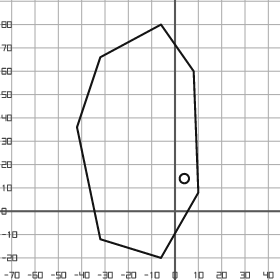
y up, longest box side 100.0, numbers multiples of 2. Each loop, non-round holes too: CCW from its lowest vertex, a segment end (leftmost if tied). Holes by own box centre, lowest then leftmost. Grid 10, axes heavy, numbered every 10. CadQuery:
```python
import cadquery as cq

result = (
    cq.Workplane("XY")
    .moveTo(-6.0, -20.0)
    .lineTo(10.0, 8.0)
    .lineTo(8.0, 60.0)
    .lineTo(-6.0, 80.0)
    .lineTo(-32.0, 66.0)
    .lineTo(-42.0, 36.0)
    .lineTo(-32.0, -12.0)
    .close()
    .moveTo(4.0, 14.0)
    .circle(2.0)
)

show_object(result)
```